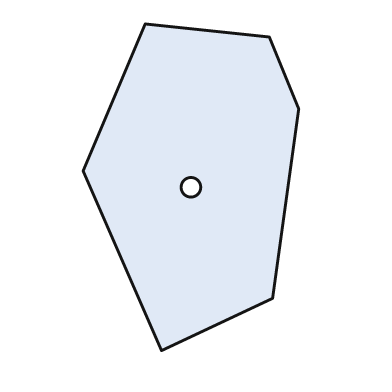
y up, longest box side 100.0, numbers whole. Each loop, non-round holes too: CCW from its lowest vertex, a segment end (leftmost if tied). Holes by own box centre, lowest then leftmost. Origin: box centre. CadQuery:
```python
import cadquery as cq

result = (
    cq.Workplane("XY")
    .moveTo(-9.0, -50.0)
    .lineTo(25.0, -34.0)
    .lineTo(33.0, 24.0)
    .lineTo(24.0, 46.0)
    .lineTo(-14.0, 50.0)
    .lineTo(-33.0, 5.0)
    .close()
    .moveTo(0.0, 0.0)
    .circle(3.0)
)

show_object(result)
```